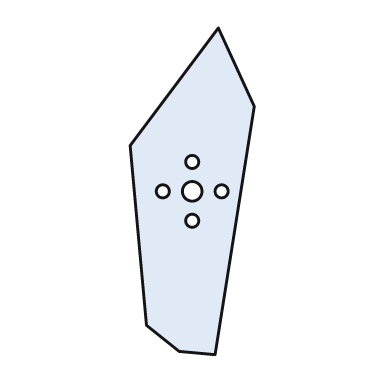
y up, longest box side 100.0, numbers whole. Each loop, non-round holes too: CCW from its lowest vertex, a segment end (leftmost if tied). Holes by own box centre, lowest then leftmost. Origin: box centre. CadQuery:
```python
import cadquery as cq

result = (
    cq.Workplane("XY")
    .moveTo(7.0, -50.0)
    .lineTo(19.0, 26.0)
    .lineTo(8.0, 50.0)
    .lineTo(-19.0, 14.0)
    .lineTo(-14.0, -41.0)
    .lineTo(-4.0, -49.0)
    .close()
    .moveTo(0.0, -9.0)
    .circle(2.0)
    .moveTo(-9.0, 0.0)
    .circle(2.0)
    .moveTo(0.0, 0.0)
    .circle(3.0)
    .moveTo(9.0, 0.0)
    .circle(2.0)
    .moveTo(0.0, 9.0)
    .circle(2.0)
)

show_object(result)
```